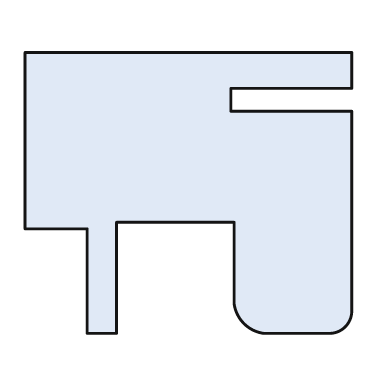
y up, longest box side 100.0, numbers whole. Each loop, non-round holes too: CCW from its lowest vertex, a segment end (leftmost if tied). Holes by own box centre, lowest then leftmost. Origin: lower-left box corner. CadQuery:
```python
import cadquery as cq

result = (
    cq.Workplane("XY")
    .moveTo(19.0, 0.0)
    .lineTo(28.0, 0.0)
    .lineTo(28.0, 34.0)
    .lineTo(64.0, 34.0)
    .lineTo(64.0, 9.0)
    .threePointArc((67.0, 3.0), (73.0, 0.0))
    .lineTo(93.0, 0.0)
    .threePointArc((98.0, 2.0), (100.0, 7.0))
    .lineTo(100.0, 68.0)
    .lineTo(63.0, 68.0)
    .lineTo(63.0, 75.0)
    .lineTo(100.0, 75.0)
    .lineTo(100.0, 86.0)
    .lineTo(0.0, 86.0)
    .lineTo(0.0, 32.0)
    .lineTo(19.0, 32.0)
    .close()
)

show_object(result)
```